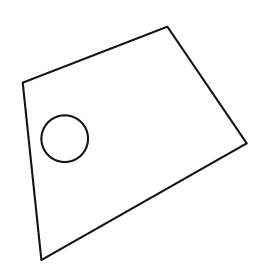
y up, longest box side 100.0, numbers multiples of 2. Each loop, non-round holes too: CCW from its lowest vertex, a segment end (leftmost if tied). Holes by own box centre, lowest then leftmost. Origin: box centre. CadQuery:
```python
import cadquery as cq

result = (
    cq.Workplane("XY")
    .moveTo(-40.0, -50.0)
    .lineTo(48.0, 0.0)
    .lineTo(14.0, 50.0)
    .lineTo(-48.0, 26.0)
    .close()
    .moveTo(-30.0, 2.0)
    .circle(10.0)
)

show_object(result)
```